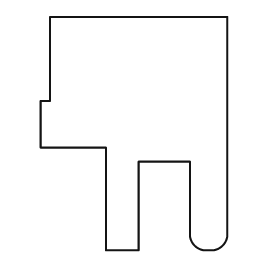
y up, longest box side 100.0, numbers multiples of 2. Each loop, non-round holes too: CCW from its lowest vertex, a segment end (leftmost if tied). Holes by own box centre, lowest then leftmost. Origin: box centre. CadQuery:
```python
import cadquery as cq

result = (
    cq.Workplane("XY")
    .moveTo(-12.0, -50.0)
    .lineTo(2.0, -50.0)
    .lineTo(2.0, -12.0)
    .lineTo(24.0, -12.0)
    .lineTo(24.0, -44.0)
    .threePointArc((26.0, -48.0), (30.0, -50.0))
    .lineTo(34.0, -50.0)
    .threePointArc((38.0, -48.0), (40.0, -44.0))
    .lineTo(40.0, 50.0)
    .lineTo(-36.0, 50.0)
    .lineTo(-36.0, 14.0)
    .lineTo(-40.0, 14.0)
    .lineTo(-40.0, -6.0)
    .lineTo(-12.0, -6.0)
    .close()
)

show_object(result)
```